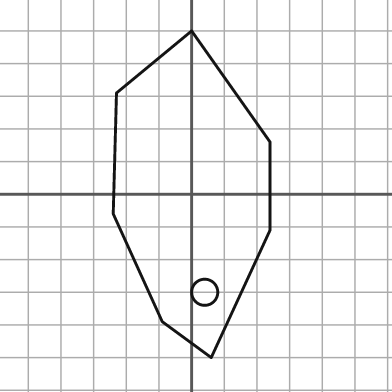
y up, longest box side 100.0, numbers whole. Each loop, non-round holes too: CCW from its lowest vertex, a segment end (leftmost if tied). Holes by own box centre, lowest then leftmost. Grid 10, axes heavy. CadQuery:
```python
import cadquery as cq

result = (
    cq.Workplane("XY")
    .moveTo(6.0, -50.0)
    .lineTo(24.0, -11.0)
    .lineTo(24.0, 16.0)
    .lineTo(0.0, 50.0)
    .lineTo(-23.0, 31.0)
    .lineTo(-24.0, -6.0)
    .lineTo(-9.0, -39.0)
    .close()
    .moveTo(4.0, -30.0)
    .circle(4.0)
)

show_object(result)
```